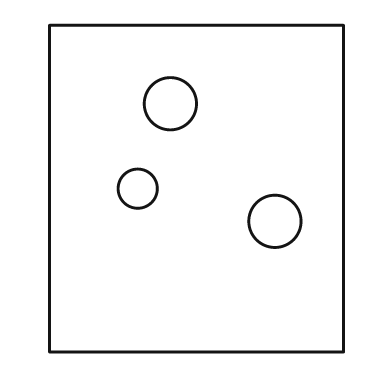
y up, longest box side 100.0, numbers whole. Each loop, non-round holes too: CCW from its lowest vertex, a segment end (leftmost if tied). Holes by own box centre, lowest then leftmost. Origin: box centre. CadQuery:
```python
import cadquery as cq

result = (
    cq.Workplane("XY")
    .moveTo(-45.0, -50.0)
    .lineTo(45.0, -50.0)
    .lineTo(45.0, 50.0)
    .lineTo(-45.0, 50.0)
    .close()
    .moveTo(24.0, -10.0)
    .circle(8.0)
    .moveTo(-18.0, 0.0)
    .circle(6.0)
    .moveTo(-8.0, 26.0)
    .circle(8.0)
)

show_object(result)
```